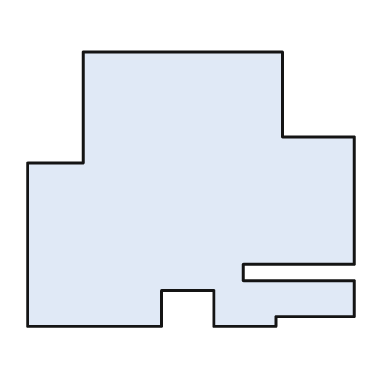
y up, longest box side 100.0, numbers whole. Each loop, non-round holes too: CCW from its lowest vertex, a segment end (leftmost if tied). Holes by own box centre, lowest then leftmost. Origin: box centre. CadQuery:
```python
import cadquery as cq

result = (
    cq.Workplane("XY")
    .moveTo(-50.0, -42.0)
    .lineTo(-9.0, -42.0)
    .lineTo(-9.0, -31.0)
    .lineTo(7.0, -31.0)
    .lineTo(7.0, -42.0)
    .lineTo(26.0, -42.0)
    .lineTo(26.0, -39.0)
    .lineTo(50.0, -39.0)
    .lineTo(50.0, -28.0)
    .lineTo(16.0, -28.0)
    .lineTo(16.0, -23.0)
    .lineTo(50.0, -23.0)
    .lineTo(50.0, 16.0)
    .lineTo(28.0, 16.0)
    .lineTo(28.0, 42.0)
    .lineTo(-33.0, 42.0)
    .lineTo(-33.0, 8.0)
    .lineTo(-50.0, 8.0)
    .close()
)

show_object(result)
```